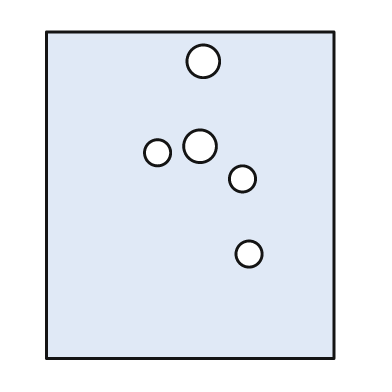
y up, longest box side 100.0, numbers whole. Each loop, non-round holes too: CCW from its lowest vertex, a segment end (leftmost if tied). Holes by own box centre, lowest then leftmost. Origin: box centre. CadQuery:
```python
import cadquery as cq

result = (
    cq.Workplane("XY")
    .moveTo(-44.0, -50.0)
    .lineTo(44.0, -50.0)
    .lineTo(44.0, 50.0)
    .lineTo(-44.0, 50.0)
    .close()
    .moveTo(18.0, -18.0)
    .circle(4.0)
    .moveTo(16.0, 5.0)
    .circle(4.0)
    .moveTo(-10.0, 13.0)
    .circle(4.0)
    .moveTo(3.0, 15.0)
    .circle(5.0)
    .moveTo(4.0, 41.0)
    .circle(5.0)
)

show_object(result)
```